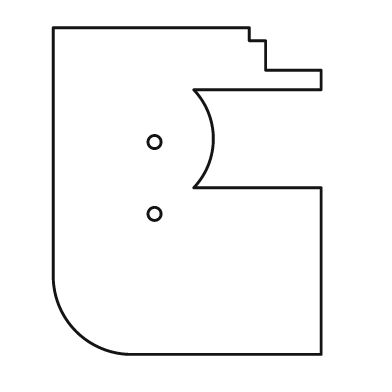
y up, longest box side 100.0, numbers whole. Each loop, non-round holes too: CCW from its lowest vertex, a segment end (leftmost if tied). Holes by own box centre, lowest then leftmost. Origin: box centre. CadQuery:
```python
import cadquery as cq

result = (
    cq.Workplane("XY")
    .moveTo(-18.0, -50.0)
    .lineTo(41.0, -50.0)
    .lineTo(41.0, 1.0)
    .lineTo(2.0, 1.0)
    .threePointArc((8.0, 16.0), (2.0, 31.0))
    .lineTo(41.0, 31.0)
    .lineTo(41.0, 37.0)
    .lineTo(24.0, 37.0)
    .lineTo(24.0, 46.0)
    .lineTo(19.0, 46.0)
    .lineTo(19.0, 50.0)
    .lineTo(-41.0, 50.0)
    .lineTo(-41.0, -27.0)
    .threePointArc((-34.0, -43.0), (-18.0, -50.0))
    .close()
    .moveTo(-10.0, -7.0)
    .circle(2.0)
    .moveTo(-10.0, 15.0)
    .circle(2.0)
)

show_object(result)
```